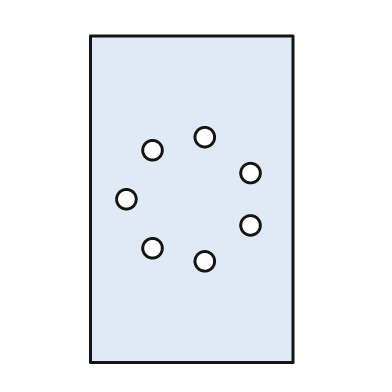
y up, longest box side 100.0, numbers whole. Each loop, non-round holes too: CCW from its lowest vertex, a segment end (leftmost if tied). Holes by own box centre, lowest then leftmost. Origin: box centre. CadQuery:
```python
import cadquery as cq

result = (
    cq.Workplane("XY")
    .moveTo(-31.0, -50.0)
    .lineTo(31.0, -50.0)
    .lineTo(31.0, 50.0)
    .lineTo(-31.0, 50.0)
    .close()
    .moveTo(4.0, -19.0)
    .circle(3.0)
    .moveTo(-12.0, -15.0)
    .circle(3.0)
    .moveTo(18.0, -8.0)
    .circle(3.0)
    .moveTo(-20.0, 0.0)
    .circle(3.0)
    .moveTo(18.0, 8.0)
    .circle(3.0)
    .moveTo(-12.0, 15.0)
    .circle(3.0)
    .moveTo(4.0, 19.0)
    .circle(3.0)
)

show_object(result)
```